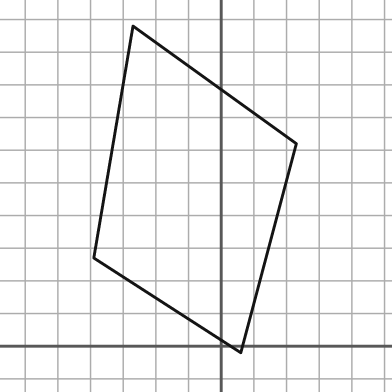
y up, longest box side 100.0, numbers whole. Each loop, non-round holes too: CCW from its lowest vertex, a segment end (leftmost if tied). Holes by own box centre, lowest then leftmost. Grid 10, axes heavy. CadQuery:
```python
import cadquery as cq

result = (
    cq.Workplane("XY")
    .moveTo(6.0, -2.0)
    .lineTo(23.0, 62.0)
    .lineTo(-27.0, 98.0)
    .lineTo(-39.0, 27.0)
    .close()
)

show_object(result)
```